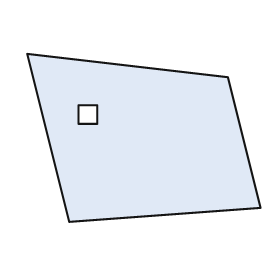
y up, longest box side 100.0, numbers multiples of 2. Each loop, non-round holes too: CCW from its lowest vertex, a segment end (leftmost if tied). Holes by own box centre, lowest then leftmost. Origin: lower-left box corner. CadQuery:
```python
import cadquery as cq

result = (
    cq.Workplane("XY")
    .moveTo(18.0, 0.0)
    .lineTo(100.0, 6.0)
    .lineTo(86.0, 62.0)
    .lineTo(0.0, 72.0)
    .close()
    .moveTo(22.0, 42.0)
    .lineTo(30.0, 42.0)
    .lineTo(30.0, 50.0)
    .lineTo(22.0, 50.0)
    .close()
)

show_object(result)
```